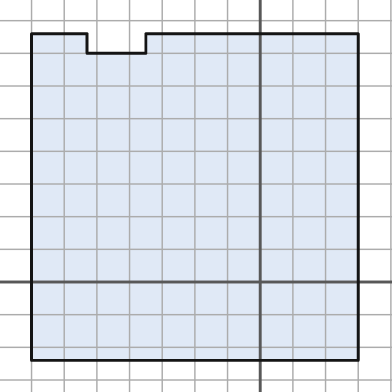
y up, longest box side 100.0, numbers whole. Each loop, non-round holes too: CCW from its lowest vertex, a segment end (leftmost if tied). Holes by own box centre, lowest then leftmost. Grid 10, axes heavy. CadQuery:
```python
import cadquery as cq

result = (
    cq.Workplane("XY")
    .moveTo(-70.0, -24.0)
    .lineTo(30.0, -24.0)
    .lineTo(30.0, 76.0)
    .lineTo(-35.0, 76.0)
    .lineTo(-35.0, 70.0)
    .lineTo(-53.0, 70.0)
    .lineTo(-53.0, 76.0)
    .lineTo(-70.0, 76.0)
    .close()
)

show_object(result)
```